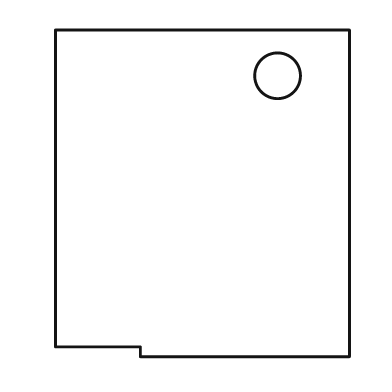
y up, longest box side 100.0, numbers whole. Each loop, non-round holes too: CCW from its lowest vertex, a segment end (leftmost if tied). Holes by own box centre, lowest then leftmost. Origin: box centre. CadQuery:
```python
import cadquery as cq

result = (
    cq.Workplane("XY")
    .moveTo(-19.0, -50.0)
    .lineTo(45.0, -50.0)
    .lineTo(45.0, 50.0)
    .lineTo(-45.0, 50.0)
    .lineTo(-45.0, -47.0)
    .lineTo(-19.0, -47.0)
    .close()
    .moveTo(23.0, 36.0)
    .circle(7.0)
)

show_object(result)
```